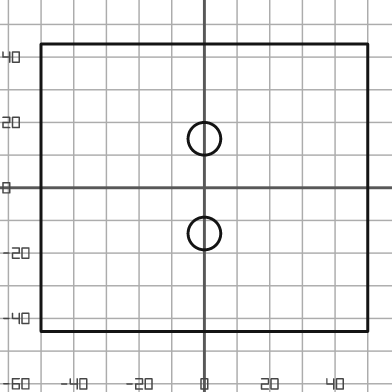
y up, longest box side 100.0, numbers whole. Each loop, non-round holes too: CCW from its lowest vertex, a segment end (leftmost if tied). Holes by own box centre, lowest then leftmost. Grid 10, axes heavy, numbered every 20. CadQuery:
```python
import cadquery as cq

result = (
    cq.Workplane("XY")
    .moveTo(-50.0, -44.0)
    .lineTo(50.0, -44.0)
    .lineTo(50.0, 44.0)
    .lineTo(-50.0, 44.0)
    .close()
    .moveTo(0.0, -14.0)
    .circle(5.0)
    .moveTo(0.0, 15.0)
    .circle(5.0)
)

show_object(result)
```